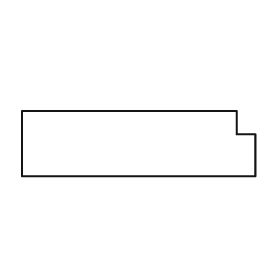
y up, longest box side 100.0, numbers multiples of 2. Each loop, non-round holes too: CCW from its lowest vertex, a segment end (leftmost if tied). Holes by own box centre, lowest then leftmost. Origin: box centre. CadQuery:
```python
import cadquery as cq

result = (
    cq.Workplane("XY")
    .moveTo(-50.0, -14.0)
    .lineTo(50.0, -14.0)
    .lineTo(50.0, 4.0)
    .lineTo(42.0, 4.0)
    .lineTo(42.0, 14.0)
    .lineTo(-50.0, 14.0)
    .close()
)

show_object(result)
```